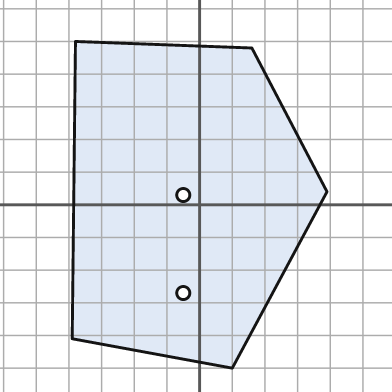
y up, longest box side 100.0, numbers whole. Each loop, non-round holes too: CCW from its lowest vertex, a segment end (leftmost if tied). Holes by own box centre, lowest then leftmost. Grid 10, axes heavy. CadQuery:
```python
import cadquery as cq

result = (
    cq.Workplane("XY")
    .moveTo(10.0, -50.0)
    .lineTo(39.0, 4.0)
    .lineTo(16.0, 48.0)
    .lineTo(-38.0, 50.0)
    .lineTo(-39.0, -41.0)
    .close()
    .moveTo(-5.0, -27.0)
    .circle(2.0)
    .moveTo(-5.0, 3.0)
    .circle(2.0)
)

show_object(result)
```